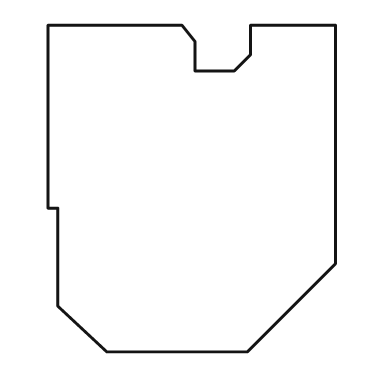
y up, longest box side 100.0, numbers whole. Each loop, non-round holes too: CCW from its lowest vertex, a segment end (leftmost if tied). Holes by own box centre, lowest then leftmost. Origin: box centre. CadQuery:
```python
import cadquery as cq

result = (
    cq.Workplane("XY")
    .moveTo(-26.0, -50.0)
    .lineTo(17.0, -50.0)
    .lineTo(44.0, -23.0)
    .lineTo(44.0, 50.0)
    .lineTo(18.0, 50.0)
    .lineTo(18.0, 41.0)
    .lineTo(13.0, 36.0)
    .lineTo(1.0, 36.0)
    .lineTo(1.0, 45.0)
    .lineTo(-3.0, 50.0)
    .lineTo(-44.0, 50.0)
    .lineTo(-44.0, -6.0)
    .lineTo(-41.0, -6.0)
    .lineTo(-41.0, -36.0)
    .close()
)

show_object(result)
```